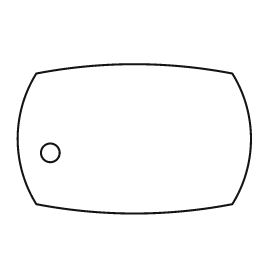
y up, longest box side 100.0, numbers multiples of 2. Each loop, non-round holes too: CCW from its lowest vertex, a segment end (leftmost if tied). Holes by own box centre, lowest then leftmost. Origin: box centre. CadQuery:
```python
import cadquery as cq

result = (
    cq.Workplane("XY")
    .moveTo(-42.0, -28.0)
    .threePointArc((0.0, -32.0), (42.0, -28.0))
    .threePointArc((50.0, 0.0), (42.0, 28.0))
    .threePointArc((0.0, 32.0), (-42.0, 28.0))
    .threePointArc((-50.0, 0.0), (-42.0, -28.0))
    .close()
    .moveTo(-36.0, -6.0)
    .circle(4.0)
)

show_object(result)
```